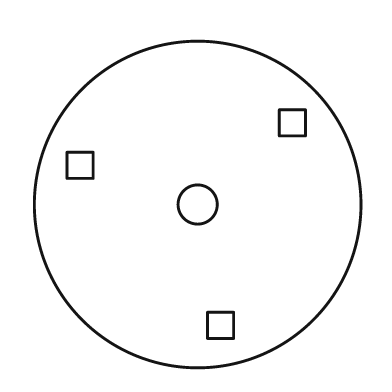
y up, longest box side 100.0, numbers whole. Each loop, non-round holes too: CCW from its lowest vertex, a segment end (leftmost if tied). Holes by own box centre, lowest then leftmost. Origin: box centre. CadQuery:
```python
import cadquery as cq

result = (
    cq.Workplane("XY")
    .moveTo(0.0, 0.0)
    .circle(50.0)
    .moveTo(3.0, -41.0)
    .lineTo(11.0, -41.0)
    .lineTo(11.0, -33.0)
    .lineTo(3.0, -33.0)
    .close()
    .moveTo(0.0, 0.0)
    .circle(6.0)
    .moveTo(-40.0, 8.0)
    .lineTo(-32.0, 8.0)
    .lineTo(-32.0, 16.0)
    .lineTo(-40.0, 16.0)
    .close()
    .moveTo(25.0, 21.0)
    .lineTo(33.0, 21.0)
    .lineTo(33.0, 29.0)
    .lineTo(25.0, 29.0)
    .close()
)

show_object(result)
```